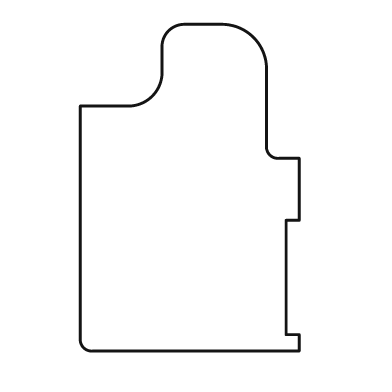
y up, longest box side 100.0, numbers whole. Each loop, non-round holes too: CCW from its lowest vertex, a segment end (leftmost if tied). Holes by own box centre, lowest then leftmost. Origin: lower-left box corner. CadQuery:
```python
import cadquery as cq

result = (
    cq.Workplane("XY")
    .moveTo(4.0, 0.0)
    .lineTo(67.0, 0.0)
    .lineTo(67.0, 5.0)
    .lineTo(63.0, 5.0)
    .lineTo(63.0, 40.0)
    .lineTo(67.0, 40.0)
    .lineTo(67.0, 59.0)
    .lineTo(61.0, 59.0)
    .threePointArc((58.0, 60.0), (57.0, 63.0))
    .lineTo(57.0, 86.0)
    .threePointArc((53.0, 96.0), (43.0, 100.0))
    .lineTo(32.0, 100.0)
    .threePointArc((27.0, 98.0), (25.0, 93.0))
    .lineTo(25.0, 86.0)
    .threePointArc((22.0, 78.0), (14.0, 75.0))
    .lineTo(0.0, 75.0)
    .lineTo(0.0, 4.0)
    .threePointArc((1.0, 1.0), (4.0, 0.0))
    .close()
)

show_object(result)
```